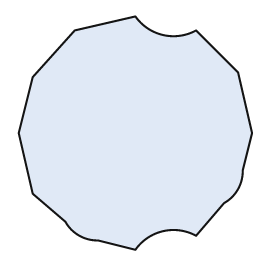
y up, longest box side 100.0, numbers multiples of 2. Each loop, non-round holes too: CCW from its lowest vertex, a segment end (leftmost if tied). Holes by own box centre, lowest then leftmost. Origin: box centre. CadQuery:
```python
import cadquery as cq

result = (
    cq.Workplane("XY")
    .moveTo(0.0, -50.0)
    .threePointArc((12.0, -42.0), (26.0, -44.0))
    .lineTo(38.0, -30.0)
    .threePointArc((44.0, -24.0), (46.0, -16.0))
    .lineTo(50.0, 0.0)
    .lineTo(44.0, 26.0)
    .lineTo(26.0, 44.0)
    .threePointArc((12.0, 42.0), (0.0, 50.0))
    .lineTo(-26.0, 44.0)
    .lineTo(-44.0, 24.0)
    .lineTo(-50.0, 0.0)
    .lineTo(-44.0, -26.0)
    .lineTo(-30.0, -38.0)
    .threePointArc((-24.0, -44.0), (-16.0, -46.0))
    .close()
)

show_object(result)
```